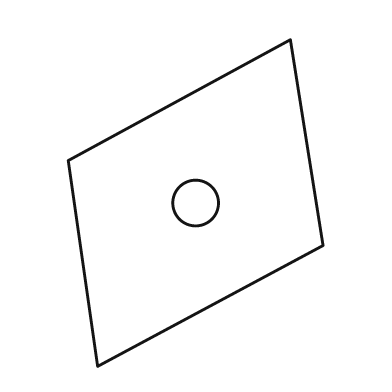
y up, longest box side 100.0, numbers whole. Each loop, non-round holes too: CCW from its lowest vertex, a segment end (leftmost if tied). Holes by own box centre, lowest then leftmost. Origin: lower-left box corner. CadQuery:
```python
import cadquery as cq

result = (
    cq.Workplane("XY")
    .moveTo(9.0, 0.0)
    .lineTo(78.0, 37.0)
    .lineTo(68.0, 100.0)
    .lineTo(0.0, 63.0)
    .close()
    .moveTo(39.0, 50.0)
    .circle(7.0)
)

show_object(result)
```